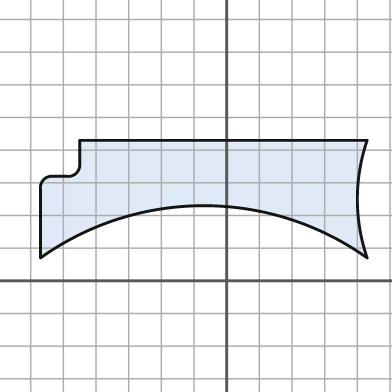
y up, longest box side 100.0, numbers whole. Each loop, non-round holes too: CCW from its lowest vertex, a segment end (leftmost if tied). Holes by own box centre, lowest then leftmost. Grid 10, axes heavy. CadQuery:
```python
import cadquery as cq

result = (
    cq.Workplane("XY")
    .moveTo(-57.0, 7.0)
    .threePointArc((-7.0, 23.0), (43.0, 7.0))
    .threePointArc((40.0, 25.0), (43.0, 43.0))
    .lineTo(-45.0, 43.0)
    .lineTo(-45.0, 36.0)
    .threePointArc((-46.0, 33.0), (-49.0, 32.0))
    .lineTo(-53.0, 32.0)
    .threePointArc((-56.0, 31.0), (-57.0, 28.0))
    .close()
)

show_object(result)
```